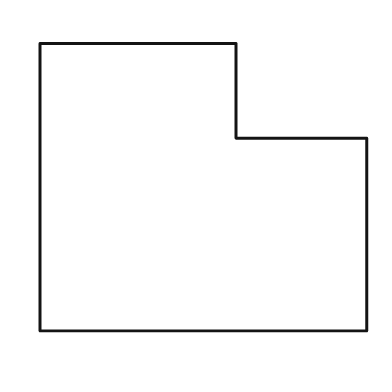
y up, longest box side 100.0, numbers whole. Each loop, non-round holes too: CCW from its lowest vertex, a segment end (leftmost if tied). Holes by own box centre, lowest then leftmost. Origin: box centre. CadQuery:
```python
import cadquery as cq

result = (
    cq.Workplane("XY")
    .moveTo(-50.0, -44.0)
    .lineTo(50.0, -44.0)
    .lineTo(50.0, 15.0)
    .lineTo(10.0, 15.0)
    .lineTo(10.0, 44.0)
    .lineTo(-50.0, 44.0)
    .close()
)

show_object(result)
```